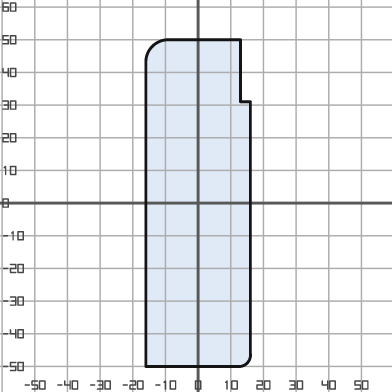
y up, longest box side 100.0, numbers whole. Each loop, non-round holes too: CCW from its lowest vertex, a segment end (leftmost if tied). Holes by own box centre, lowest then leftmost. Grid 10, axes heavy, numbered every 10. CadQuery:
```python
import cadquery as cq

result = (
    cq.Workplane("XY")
    .moveTo(-16.0, -50.0)
    .lineTo(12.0, -50.0)
    .threePointArc((15.0, -49.0), (16.0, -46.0))
    .lineTo(16.0, 31.0)
    .lineTo(13.0, 31.0)
    .lineTo(13.0, 50.0)
    .lineTo(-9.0, 50.0)
    .threePointArc((-14.0, 48.0), (-16.0, 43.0))
    .close()
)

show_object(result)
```